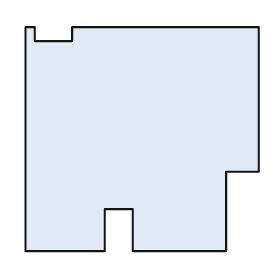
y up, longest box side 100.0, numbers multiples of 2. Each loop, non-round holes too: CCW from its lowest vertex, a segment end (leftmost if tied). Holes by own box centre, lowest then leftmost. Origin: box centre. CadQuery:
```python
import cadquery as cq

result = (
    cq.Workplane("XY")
    .moveTo(-50.0, -48.0)
    .lineTo(-16.0, -48.0)
    .lineTo(-16.0, -30.0)
    .lineTo(-4.0, -30.0)
    .lineTo(-4.0, -48.0)
    .lineTo(36.0, -48.0)
    .lineTo(36.0, -14.0)
    .lineTo(50.0, -14.0)
    .lineTo(50.0, 48.0)
    .lineTo(-30.0, 48.0)
    .lineTo(-30.0, 42.0)
    .lineTo(-46.0, 42.0)
    .lineTo(-46.0, 48.0)
    .lineTo(-50.0, 48.0)
    .close()
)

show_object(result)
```